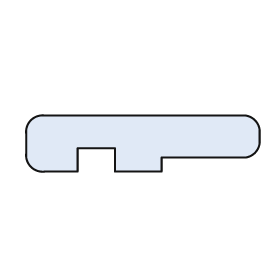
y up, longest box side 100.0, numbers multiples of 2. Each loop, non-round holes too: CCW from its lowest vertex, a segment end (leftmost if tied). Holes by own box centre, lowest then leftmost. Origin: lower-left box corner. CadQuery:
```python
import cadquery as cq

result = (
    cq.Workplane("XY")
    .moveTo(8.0, 0.0)
    .lineTo(22.0, 0.0)
    .lineTo(22.0, 10.0)
    .lineTo(38.0, 10.0)
    .lineTo(38.0, 0.0)
    .lineTo(58.0, 0.0)
    .lineTo(58.0, 6.0)
    .lineTo(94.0, 6.0)
    .threePointArc((98.0, 8.0), (100.0, 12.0))
    .lineTo(100.0, 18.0)
    .threePointArc((98.0, 22.0), (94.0, 24.0))
    .lineTo(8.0, 24.0)
    .threePointArc((2.0, 22.0), (0.0, 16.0))
    .lineTo(0.0, 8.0)
    .threePointArc((2.0, 2.0), (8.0, 0.0))
    .close()
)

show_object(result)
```